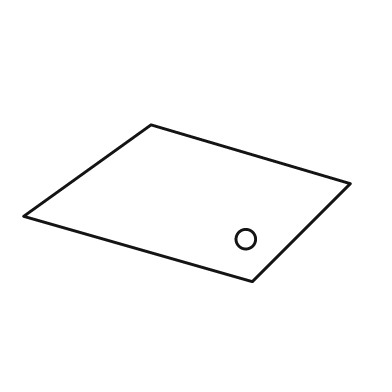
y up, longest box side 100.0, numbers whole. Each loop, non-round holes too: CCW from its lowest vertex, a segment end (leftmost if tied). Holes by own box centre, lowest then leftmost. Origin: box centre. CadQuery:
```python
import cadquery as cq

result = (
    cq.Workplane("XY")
    .moveTo(20.0, -24.0)
    .lineTo(50.0, 6.0)
    .lineTo(-11.0, 24.0)
    .lineTo(-50.0, -4.0)
    .close()
    .moveTo(18.0, -11.0)
    .circle(3.0)
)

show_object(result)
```